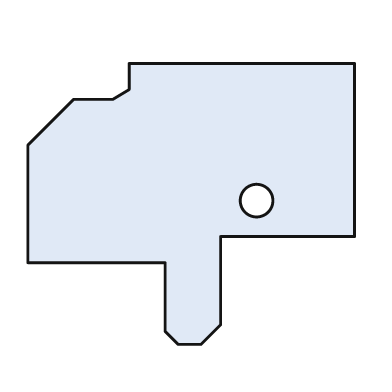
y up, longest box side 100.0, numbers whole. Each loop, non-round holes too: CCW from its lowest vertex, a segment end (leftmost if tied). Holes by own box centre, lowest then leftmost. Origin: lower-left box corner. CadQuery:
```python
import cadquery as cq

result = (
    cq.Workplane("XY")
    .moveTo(46.0, 0.0)
    .lineTo(53.0, 0.0)
    .lineTo(59.0, 6.0)
    .lineTo(59.0, 33.0)
    .lineTo(100.0, 33.0)
    .lineTo(100.0, 86.0)
    .lineTo(31.0, 86.0)
    .lineTo(31.0, 78.0)
    .lineTo(26.0, 75.0)
    .lineTo(14.0, 75.0)
    .lineTo(0.0, 61.0)
    .lineTo(0.0, 25.0)
    .lineTo(42.0, 25.0)
    .lineTo(42.0, 4.0)
    .close()
    .moveTo(70.0, 44.0)
    .circle(5.0)
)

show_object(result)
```